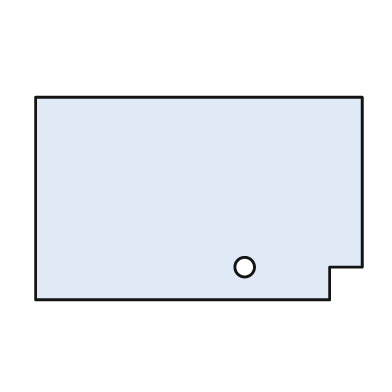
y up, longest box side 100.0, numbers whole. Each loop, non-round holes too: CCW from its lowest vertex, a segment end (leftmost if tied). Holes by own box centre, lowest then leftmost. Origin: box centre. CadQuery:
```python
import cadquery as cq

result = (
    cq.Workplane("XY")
    .moveTo(-50.0, -31.0)
    .lineTo(40.0, -31.0)
    .lineTo(40.0, -21.0)
    .lineTo(50.0, -21.0)
    .lineTo(50.0, 31.0)
    .lineTo(-50.0, 31.0)
    .close()
    .moveTo(14.0, -21.0)
    .circle(3.0)
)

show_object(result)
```